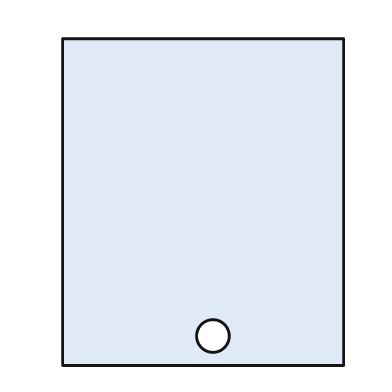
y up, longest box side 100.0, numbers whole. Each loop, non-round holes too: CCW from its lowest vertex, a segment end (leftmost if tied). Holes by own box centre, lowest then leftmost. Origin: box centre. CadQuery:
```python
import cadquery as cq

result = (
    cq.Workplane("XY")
    .moveTo(-43.0, -50.0)
    .lineTo(43.0, -50.0)
    .lineTo(43.0, 50.0)
    .lineTo(-43.0, 50.0)
    .close()
    .moveTo(3.0, -41.0)
    .circle(5.0)
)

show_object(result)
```